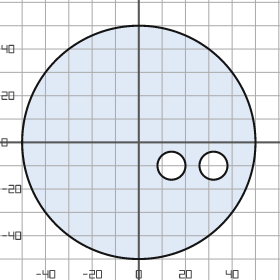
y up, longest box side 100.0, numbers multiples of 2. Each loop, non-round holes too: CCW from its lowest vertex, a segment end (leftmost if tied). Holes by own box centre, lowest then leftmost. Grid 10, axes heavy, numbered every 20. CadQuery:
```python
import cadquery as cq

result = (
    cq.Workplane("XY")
    .moveTo(0.0, 0.0)
    .circle(50.0)
    .moveTo(14.0, -10.0)
    .circle(6.0)
    .moveTo(32.0, -10.0)
    .circle(6.0)
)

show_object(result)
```